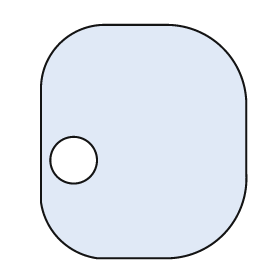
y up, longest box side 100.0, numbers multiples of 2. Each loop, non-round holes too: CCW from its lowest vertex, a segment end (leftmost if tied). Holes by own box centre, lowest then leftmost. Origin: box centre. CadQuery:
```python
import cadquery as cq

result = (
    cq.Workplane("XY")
    .moveTo(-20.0, -50.0)
    .lineTo(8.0, -50.0)
    .threePointArc((34.0, -40.0), (44.0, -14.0))
    .lineTo(44.0, 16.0)
    .threePointArc((34.0, 40.0), (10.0, 50.0))
    .lineTo(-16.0, 50.0)
    .threePointArc((-36.0, 42.0), (-44.0, 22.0))
    .lineTo(-44.0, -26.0)
    .threePointArc((-36.0, -42.0), (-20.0, -50.0))
    .close()
    .moveTo(-30.0, -8.0)
    .circle(10.0)
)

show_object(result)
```